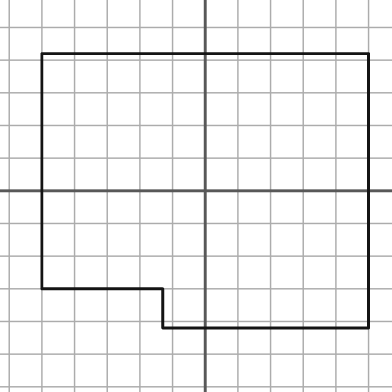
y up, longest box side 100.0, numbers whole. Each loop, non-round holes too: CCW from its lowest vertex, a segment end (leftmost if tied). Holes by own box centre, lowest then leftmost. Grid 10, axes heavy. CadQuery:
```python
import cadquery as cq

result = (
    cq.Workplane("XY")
    .moveTo(-13.0, -42.0)
    .lineTo(50.0, -42.0)
    .lineTo(50.0, 42.0)
    .lineTo(-50.0, 42.0)
    .lineTo(-50.0, -30.0)
    .lineTo(-13.0, -30.0)
    .close()
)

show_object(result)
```